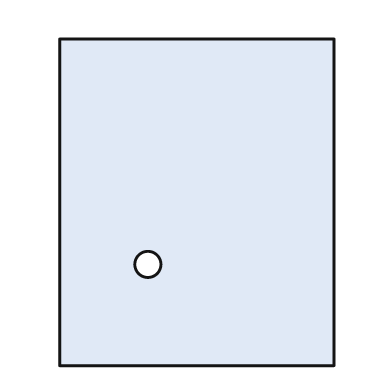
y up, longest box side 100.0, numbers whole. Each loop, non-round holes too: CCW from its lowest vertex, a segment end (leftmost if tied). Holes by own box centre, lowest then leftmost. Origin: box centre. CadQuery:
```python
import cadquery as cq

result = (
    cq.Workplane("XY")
    .moveTo(-42.0, -50.0)
    .lineTo(42.0, -50.0)
    .lineTo(42.0, 50.0)
    .lineTo(-42.0, 50.0)
    .close()
    .moveTo(-15.0, -19.0)
    .circle(4.0)
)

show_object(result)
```